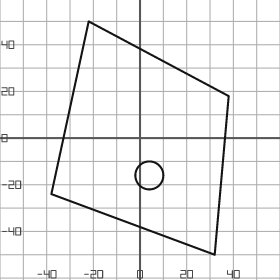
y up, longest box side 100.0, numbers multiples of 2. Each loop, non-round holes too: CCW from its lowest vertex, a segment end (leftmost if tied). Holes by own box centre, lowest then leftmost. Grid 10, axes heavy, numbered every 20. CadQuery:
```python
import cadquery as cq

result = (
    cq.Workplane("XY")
    .moveTo(32.0, -50.0)
    .lineTo(38.0, 18.0)
    .lineTo(-22.0, 50.0)
    .lineTo(-38.0, -24.0)
    .close()
    .moveTo(4.0, -16.0)
    .circle(6.0)
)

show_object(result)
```